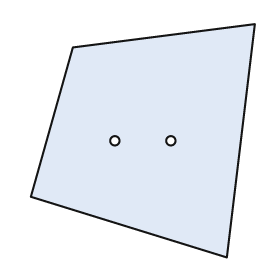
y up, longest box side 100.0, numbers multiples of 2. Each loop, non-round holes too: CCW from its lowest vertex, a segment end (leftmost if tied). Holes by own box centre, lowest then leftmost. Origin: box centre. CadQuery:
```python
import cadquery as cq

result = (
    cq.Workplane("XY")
    .moveTo(36.0, -50.0)
    .lineTo(48.0, 50.0)
    .lineTo(-30.0, 40.0)
    .lineTo(-48.0, -24.0)
    .close()
    .moveTo(-12.0, 0.0)
    .circle(2.0)
    .moveTo(12.0, 0.0)
    .circle(2.0)
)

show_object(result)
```